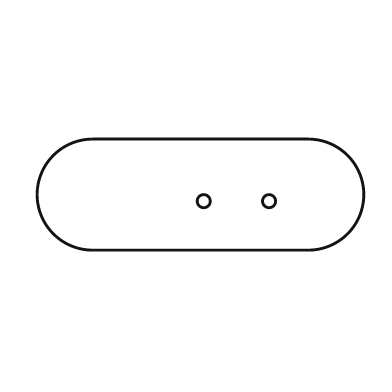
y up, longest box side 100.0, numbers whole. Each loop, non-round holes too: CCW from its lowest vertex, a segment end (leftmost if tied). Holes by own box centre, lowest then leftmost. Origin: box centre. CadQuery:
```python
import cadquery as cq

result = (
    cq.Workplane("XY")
    .moveTo(-33.0, -17.0)
    .lineTo(33.0, -17.0)
    .threePointArc((50.0, 0.0), (33.0, 17.0))
    .lineTo(-33.0, 17.0)
    .threePointArc((-50.0, 0.0), (-33.0, -17.0))
    .close()
    .moveTo(1.0, -2.0)
    .circle(2.0)
    .moveTo(21.0, -2.0)
    .circle(2.0)
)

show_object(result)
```